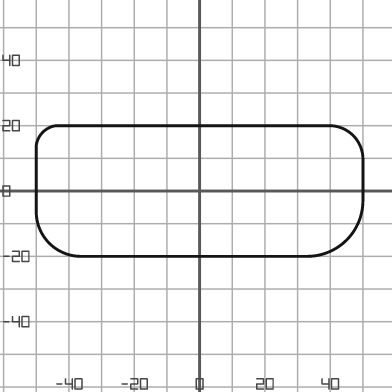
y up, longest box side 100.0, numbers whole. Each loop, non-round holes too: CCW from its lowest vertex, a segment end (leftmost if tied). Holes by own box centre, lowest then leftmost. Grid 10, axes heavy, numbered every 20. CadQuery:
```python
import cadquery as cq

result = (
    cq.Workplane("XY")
    .moveTo(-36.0, -20.0)
    .lineTo(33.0, -20.0)
    .threePointArc((45.0, -15.0), (50.0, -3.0))
    .lineTo(50.0, 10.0)
    .threePointArc((47.0, 17.0), (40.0, 20.0))
    .lineTo(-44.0, 20.0)
    .threePointArc((-48.0, 18.0), (-50.0, 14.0))
    .lineTo(-50.0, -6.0)
    .threePointArc((-46.0, -16.0), (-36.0, -20.0))
    .close()
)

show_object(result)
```